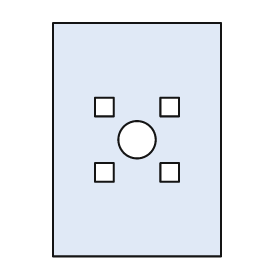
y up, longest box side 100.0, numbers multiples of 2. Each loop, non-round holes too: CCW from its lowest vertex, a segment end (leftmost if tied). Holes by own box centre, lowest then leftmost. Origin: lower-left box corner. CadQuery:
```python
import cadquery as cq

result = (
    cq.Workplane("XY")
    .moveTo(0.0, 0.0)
    .lineTo(72.0, 0.0)
    .lineTo(72.0, 100.0)
    .lineTo(0.0, 100.0)
    .close()
    .moveTo(18.0, 32.0)
    .lineTo(26.0, 32.0)
    .lineTo(26.0, 40.0)
    .lineTo(18.0, 40.0)
    .close()
    .moveTo(46.0, 32.0)
    .lineTo(54.0, 32.0)
    .lineTo(54.0, 40.0)
    .lineTo(46.0, 40.0)
    .close()
    .moveTo(36.0, 50.0)
    .circle(8.0)
    .moveTo(18.0, 60.0)
    .lineTo(26.0, 60.0)
    .lineTo(26.0, 68.0)
    .lineTo(18.0, 68.0)
    .close()
    .moveTo(46.0, 60.0)
    .lineTo(54.0, 60.0)
    .lineTo(54.0, 68.0)
    .lineTo(46.0, 68.0)
    .close()
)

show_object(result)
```